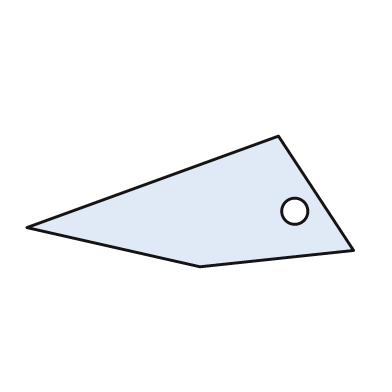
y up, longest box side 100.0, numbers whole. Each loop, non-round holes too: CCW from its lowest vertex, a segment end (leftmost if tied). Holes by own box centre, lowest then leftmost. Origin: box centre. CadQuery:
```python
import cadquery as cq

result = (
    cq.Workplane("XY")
    .moveTo(3.0, -20.0)
    .lineTo(50.0, -15.0)
    .lineTo(27.0, 20.0)
    .lineTo(-50.0, -8.0)
    .close()
    .moveTo(32.0, -3.0)
    .circle(4.0)
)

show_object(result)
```